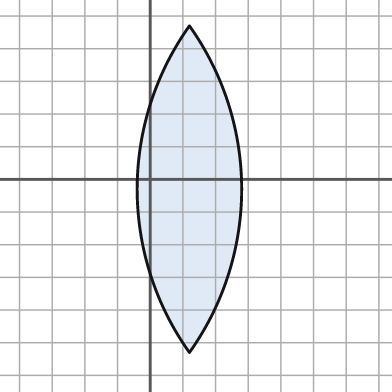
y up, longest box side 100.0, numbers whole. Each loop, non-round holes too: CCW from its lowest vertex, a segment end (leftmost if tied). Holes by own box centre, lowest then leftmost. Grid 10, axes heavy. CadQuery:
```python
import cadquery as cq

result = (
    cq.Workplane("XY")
    .moveTo(12.0, -53.0)
    .threePointArc((28.0, -3.0), (12.0, 47.0))
    .threePointArc((-4.0, -3.0), (12.0, -53.0))
    .close()
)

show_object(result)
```